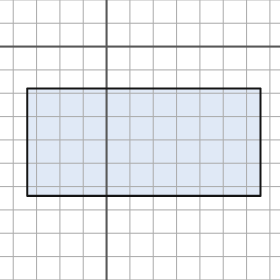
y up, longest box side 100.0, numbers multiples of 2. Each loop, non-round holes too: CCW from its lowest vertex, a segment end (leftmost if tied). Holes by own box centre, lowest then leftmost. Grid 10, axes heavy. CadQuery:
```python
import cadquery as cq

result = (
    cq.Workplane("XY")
    .moveTo(-34.0, -64.0)
    .lineTo(66.0, -64.0)
    .lineTo(66.0, -18.0)
    .lineTo(-34.0, -18.0)
    .close()
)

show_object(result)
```